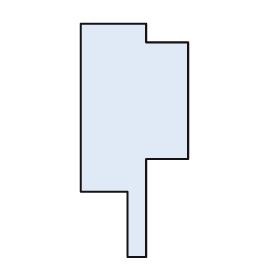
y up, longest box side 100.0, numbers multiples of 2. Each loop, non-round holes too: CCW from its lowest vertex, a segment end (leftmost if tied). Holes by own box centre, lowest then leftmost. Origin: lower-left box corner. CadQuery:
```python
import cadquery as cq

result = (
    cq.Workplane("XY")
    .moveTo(20.0, 0.0)
    .lineTo(28.0, 0.0)
    .lineTo(28.0, 42.0)
    .lineTo(46.0, 42.0)
    .lineTo(46.0, 92.0)
    .lineTo(28.0, 92.0)
    .lineTo(28.0, 100.0)
    .lineTo(0.0, 100.0)
    .lineTo(0.0, 28.0)
    .lineTo(20.0, 28.0)
    .close()
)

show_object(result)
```